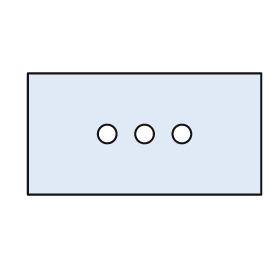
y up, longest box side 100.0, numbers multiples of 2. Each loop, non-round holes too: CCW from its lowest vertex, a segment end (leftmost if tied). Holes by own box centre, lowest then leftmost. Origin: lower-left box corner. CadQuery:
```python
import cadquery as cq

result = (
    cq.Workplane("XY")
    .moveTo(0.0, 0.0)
    .lineTo(100.0, 0.0)
    .lineTo(100.0, 52.0)
    .lineTo(0.0, 52.0)
    .close()
    .moveTo(34.0, 26.0)
    .circle(4.0)
    .moveTo(50.0, 26.0)
    .circle(4.0)
    .moveTo(66.0, 26.0)
    .circle(4.0)
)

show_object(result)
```